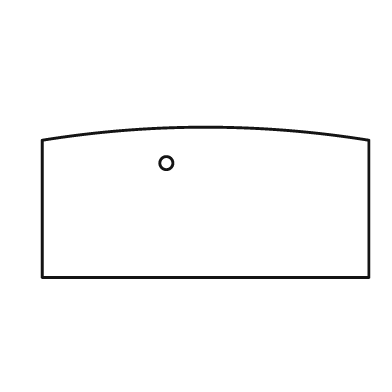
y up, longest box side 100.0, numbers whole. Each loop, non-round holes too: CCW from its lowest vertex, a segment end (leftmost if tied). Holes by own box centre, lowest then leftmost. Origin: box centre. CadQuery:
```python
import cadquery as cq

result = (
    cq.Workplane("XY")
    .moveTo(-50.0, -23.0)
    .lineTo(50.0, -23.0)
    .lineTo(50.0, 19.0)
    .threePointArc((0.0, 23.0), (-50.0, 19.0))
    .close()
    .moveTo(-12.0, 12.0)
    .circle(2.0)
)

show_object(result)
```